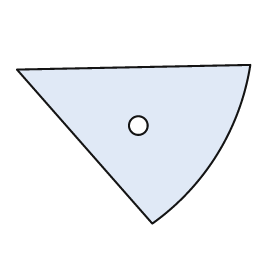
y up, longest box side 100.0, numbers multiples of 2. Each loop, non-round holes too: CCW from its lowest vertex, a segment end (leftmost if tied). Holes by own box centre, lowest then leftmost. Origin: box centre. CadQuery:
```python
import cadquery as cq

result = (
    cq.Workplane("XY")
    .moveTo(8.0, -34.0)
    .threePointArc((36.0, -4.0), (50.0, 34.0))
    .lineTo(-50.0, 32.0)
    .close()
    .moveTo(2.0, 8.0)
    .circle(4.0)
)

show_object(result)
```